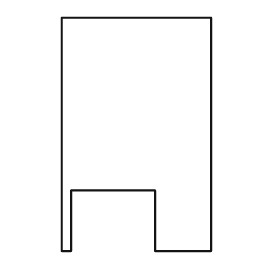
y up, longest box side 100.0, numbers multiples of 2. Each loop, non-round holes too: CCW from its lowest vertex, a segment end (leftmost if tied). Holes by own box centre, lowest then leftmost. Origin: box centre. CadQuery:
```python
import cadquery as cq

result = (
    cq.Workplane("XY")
    .moveTo(-32.0, -50.0)
    .lineTo(-28.0, -50.0)
    .lineTo(-28.0, -24.0)
    .lineTo(8.0, -24.0)
    .lineTo(8.0, -50.0)
    .lineTo(32.0, -50.0)
    .lineTo(32.0, 50.0)
    .lineTo(-32.0, 50.0)
    .close()
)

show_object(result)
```